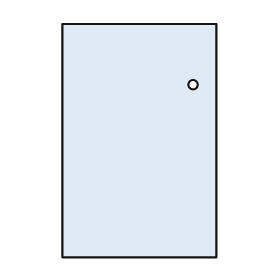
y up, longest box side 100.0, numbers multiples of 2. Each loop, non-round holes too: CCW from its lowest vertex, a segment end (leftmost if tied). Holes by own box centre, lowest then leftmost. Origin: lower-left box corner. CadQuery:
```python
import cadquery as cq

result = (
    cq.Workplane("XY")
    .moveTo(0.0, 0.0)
    .lineTo(66.0, 0.0)
    .lineTo(66.0, 100.0)
    .lineTo(0.0, 100.0)
    .close()
    .moveTo(56.0, 74.0)
    .circle(2.0)
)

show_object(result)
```